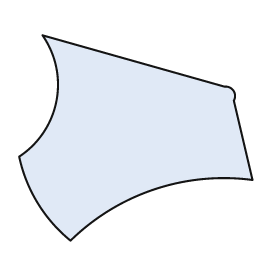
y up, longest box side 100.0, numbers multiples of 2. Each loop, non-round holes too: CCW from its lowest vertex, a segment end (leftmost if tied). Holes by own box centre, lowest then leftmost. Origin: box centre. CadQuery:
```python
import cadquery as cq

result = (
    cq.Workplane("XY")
    .moveTo(-28.0, -44.0)
    .threePointArc((8.0, -22.0), (50.0, -18.0))
    .lineTo(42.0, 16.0)
    .threePointArc((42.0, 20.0), (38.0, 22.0))
    .lineTo(-40.0, 44.0)
    .threePointArc((-34.0, 16.0), (-50.0, -8.0))
    .threePointArc((-42.0, -28.0), (-28.0, -44.0))
    .close()
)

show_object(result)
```